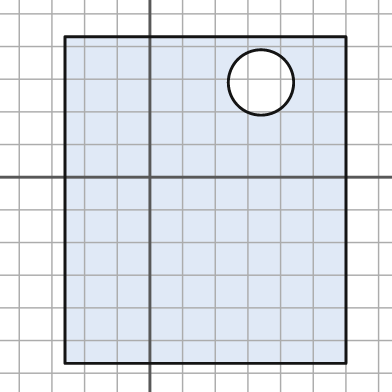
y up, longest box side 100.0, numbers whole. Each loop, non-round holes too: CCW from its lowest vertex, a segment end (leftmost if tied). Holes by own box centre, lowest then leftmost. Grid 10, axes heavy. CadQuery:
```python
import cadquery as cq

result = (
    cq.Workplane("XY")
    .moveTo(-26.0, -57.0)
    .lineTo(60.0, -57.0)
    .lineTo(60.0, 43.0)
    .lineTo(-26.0, 43.0)
    .close()
    .moveTo(34.0, 29.0)
    .circle(10.0)
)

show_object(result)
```